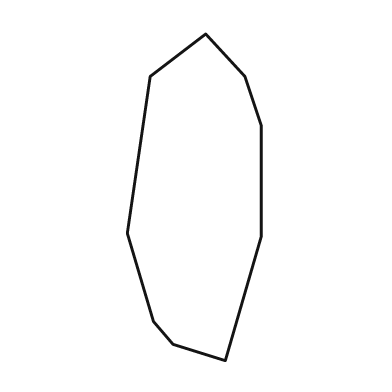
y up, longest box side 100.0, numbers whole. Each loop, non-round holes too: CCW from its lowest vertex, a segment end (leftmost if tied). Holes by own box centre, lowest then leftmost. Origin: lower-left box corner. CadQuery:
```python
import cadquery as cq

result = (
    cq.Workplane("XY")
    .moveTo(30.0, 0.0)
    .lineTo(41.0, 38.0)
    .lineTo(41.0, 72.0)
    .lineTo(36.0, 87.0)
    .lineTo(24.0, 100.0)
    .lineTo(7.0, 87.0)
    .lineTo(0.0, 39.0)
    .lineTo(8.0, 12.0)
    .lineTo(14.0, 5.0)
    .close()
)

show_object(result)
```